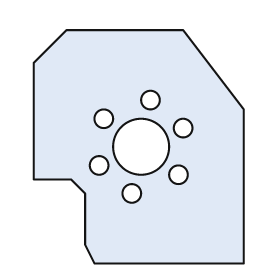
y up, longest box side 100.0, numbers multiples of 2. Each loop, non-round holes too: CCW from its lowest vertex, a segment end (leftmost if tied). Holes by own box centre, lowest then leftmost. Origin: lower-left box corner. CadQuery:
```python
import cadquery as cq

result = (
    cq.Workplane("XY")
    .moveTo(26.0, 0.0)
    .lineTo(90.0, 0.0)
    .lineTo(90.0, 66.0)
    .lineTo(64.0, 100.0)
    .lineTo(14.0, 100.0)
    .lineTo(0.0, 86.0)
    .lineTo(0.0, 36.0)
    .lineTo(16.0, 36.0)
    .lineTo(22.0, 30.0)
    .lineTo(22.0, 8.0)
    .close()
    .moveTo(42.0, 30.0)
    .circle(4.0)
    .moveTo(62.0, 38.0)
    .circle(4.0)
    .moveTo(28.0, 42.0)
    .circle(4.0)
    .moveTo(46.0, 50.0)
    .circle(12.0)
    .moveTo(64.0, 58.0)
    .circle(4.0)
    .moveTo(30.0, 62.0)
    .circle(4.0)
    .moveTo(50.0, 70.0)
    .circle(4.0)
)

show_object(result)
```